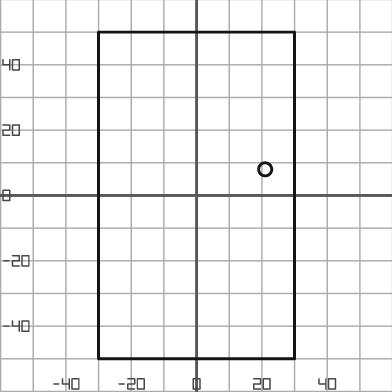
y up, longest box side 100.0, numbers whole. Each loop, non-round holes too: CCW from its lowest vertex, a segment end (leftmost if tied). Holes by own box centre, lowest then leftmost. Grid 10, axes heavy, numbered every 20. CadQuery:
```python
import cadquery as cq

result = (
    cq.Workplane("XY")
    .moveTo(-30.0, -50.0)
    .lineTo(30.0, -50.0)
    .lineTo(30.0, 50.0)
    .lineTo(-30.0, 50.0)
    .close()
    .moveTo(21.0, 8.0)
    .circle(2.0)
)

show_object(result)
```